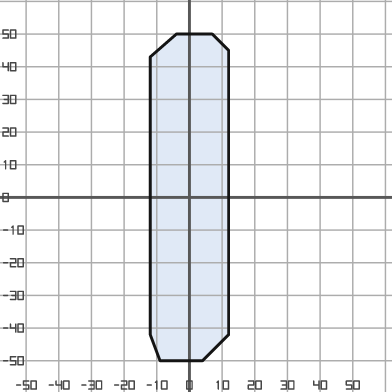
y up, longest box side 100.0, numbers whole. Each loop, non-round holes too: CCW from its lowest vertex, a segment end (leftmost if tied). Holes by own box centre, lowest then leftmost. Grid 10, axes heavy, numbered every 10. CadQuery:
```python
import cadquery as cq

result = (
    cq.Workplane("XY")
    .moveTo(-9.0, -50.0)
    .lineTo(4.0, -50.0)
    .lineTo(12.0, -42.0)
    .lineTo(12.0, 45.0)
    .lineTo(7.0, 50.0)
    .lineTo(-4.0, 50.0)
    .lineTo(-12.0, 43.0)
    .lineTo(-12.0, -42.0)
    .close()
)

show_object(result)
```